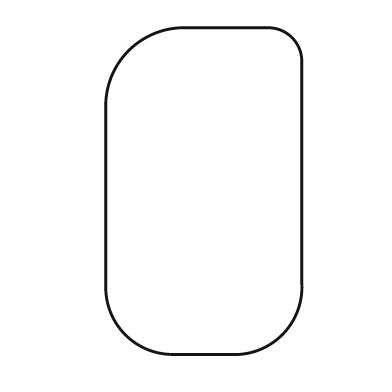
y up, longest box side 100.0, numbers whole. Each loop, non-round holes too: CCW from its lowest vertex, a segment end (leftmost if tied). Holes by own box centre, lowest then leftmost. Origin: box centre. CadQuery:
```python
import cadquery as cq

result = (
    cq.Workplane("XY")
    .moveTo(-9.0, -50.0)
    .lineTo(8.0, -50.0)
    .threePointArc((24.0, -44.0), (30.0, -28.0))
    .lineTo(30.0, 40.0)
    .threePointArc((27.0, 47.0), (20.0, 50.0))
    .lineTo(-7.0, 50.0)
    .threePointArc((-23.0, 43.0), (-30.0, 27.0))
    .lineTo(-30.0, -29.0)
    .threePointArc((-24.0, -44.0), (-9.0, -50.0))
    .close()
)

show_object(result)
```